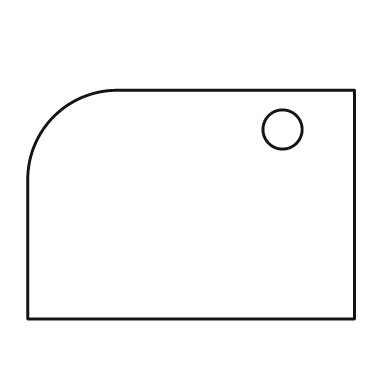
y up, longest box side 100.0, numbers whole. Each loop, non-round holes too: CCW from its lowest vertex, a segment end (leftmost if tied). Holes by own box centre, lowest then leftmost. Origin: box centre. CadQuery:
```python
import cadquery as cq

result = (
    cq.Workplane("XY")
    .moveTo(-50.0, -35.0)
    .lineTo(50.0, -35.0)
    .lineTo(50.0, 35.0)
    .lineTo(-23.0, 35.0)
    .threePointArc((-42.0, 27.0), (-50.0, 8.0))
    .close()
    .moveTo(28.0, 23.0)
    .circle(6.0)
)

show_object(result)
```